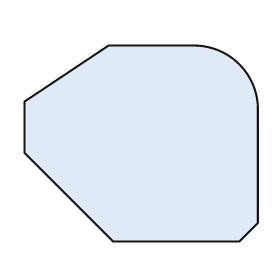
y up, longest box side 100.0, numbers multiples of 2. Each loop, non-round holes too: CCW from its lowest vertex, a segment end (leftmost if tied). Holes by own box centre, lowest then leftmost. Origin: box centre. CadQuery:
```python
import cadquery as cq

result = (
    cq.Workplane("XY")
    .moveTo(-12.0, -42.0)
    .lineTo(42.0, -42.0)
    .lineTo(50.0, -34.0)
    .lineTo(50.0, 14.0)
    .threePointArc((42.0, 34.0), (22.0, 42.0))
    .lineTo(-14.0, 42.0)
    .lineTo(-50.0, 18.0)
    .lineTo(-50.0, -4.0)
    .close()
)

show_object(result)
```